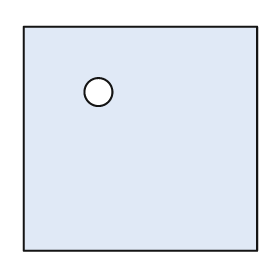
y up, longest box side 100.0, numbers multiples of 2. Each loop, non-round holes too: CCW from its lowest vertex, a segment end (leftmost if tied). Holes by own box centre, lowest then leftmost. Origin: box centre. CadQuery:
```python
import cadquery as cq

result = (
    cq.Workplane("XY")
    .moveTo(-50.0, -48.0)
    .lineTo(50.0, -48.0)
    .lineTo(50.0, 48.0)
    .lineTo(-50.0, 48.0)
    .close()
    .moveTo(-18.0, 20.0)
    .circle(6.0)
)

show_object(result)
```